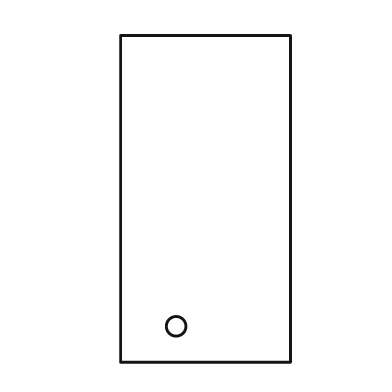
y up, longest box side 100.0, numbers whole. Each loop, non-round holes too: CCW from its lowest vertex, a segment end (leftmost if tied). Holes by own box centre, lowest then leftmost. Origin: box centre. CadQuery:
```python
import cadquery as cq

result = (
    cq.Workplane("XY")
    .moveTo(-26.0, -50.0)
    .lineTo(26.0, -50.0)
    .lineTo(26.0, 50.0)
    .lineTo(-26.0, 50.0)
    .close()
    .moveTo(-9.0, -39.0)
    .circle(3.0)
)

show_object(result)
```